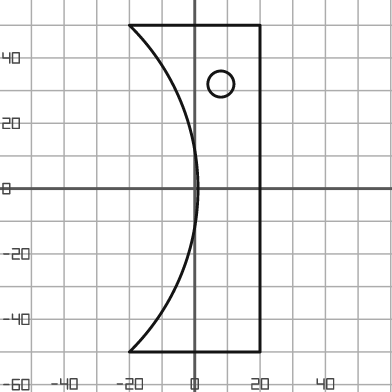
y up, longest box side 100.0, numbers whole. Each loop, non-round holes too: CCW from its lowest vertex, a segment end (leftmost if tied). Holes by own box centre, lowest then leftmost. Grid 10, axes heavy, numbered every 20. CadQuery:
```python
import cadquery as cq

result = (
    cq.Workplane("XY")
    .moveTo(-20.0, -50.0)
    .lineTo(20.0, -50.0)
    .lineTo(20.0, 50.0)
    .lineTo(-20.0, 50.0)
    .threePointArc((1.0, 0.0), (-20.0, -50.0))
    .close()
    .moveTo(8.0, 32.0)
    .circle(4.0)
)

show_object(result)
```